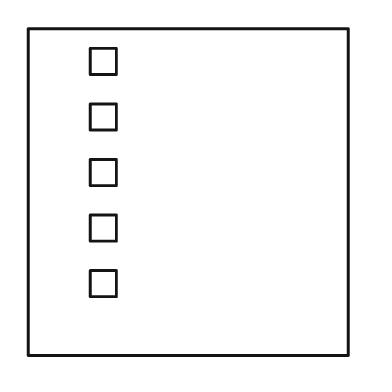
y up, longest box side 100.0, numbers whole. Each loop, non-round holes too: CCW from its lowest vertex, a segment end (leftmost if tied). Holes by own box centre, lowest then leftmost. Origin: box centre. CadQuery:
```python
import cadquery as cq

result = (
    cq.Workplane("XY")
    .moveTo(-49.0, -50.0)
    .lineTo(49.0, -50.0)
    .lineTo(49.0, 50.0)
    .lineTo(-49.0, 50.0)
    .close()
    .moveTo(-30.0, -32.0)
    .lineTo(-22.0, -32.0)
    .lineTo(-22.0, -24.0)
    .lineTo(-30.0, -24.0)
    .close()
    .moveTo(-30.0, -15.0)
    .lineTo(-22.0, -15.0)
    .lineTo(-22.0, -7.0)
    .lineTo(-30.0, -7.0)
    .close()
    .moveTo(-30.0, 2.0)
    .lineTo(-22.0, 2.0)
    .lineTo(-22.0, 10.0)
    .lineTo(-30.0, 10.0)
    .close()
    .moveTo(-30.0, 19.0)
    .lineTo(-22.0, 19.0)
    .lineTo(-22.0, 27.0)
    .lineTo(-30.0, 27.0)
    .close()
    .moveTo(-30.0, 36.0)
    .lineTo(-22.0, 36.0)
    .lineTo(-22.0, 44.0)
    .lineTo(-30.0, 44.0)
    .close()
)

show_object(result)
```